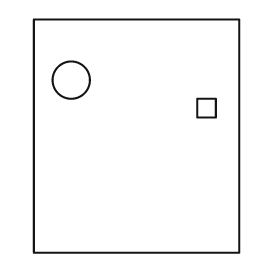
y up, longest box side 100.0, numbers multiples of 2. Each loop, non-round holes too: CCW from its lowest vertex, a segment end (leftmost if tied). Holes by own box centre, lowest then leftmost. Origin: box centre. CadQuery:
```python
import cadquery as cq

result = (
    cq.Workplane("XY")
    .moveTo(-44.0, -50.0)
    .lineTo(44.0, -50.0)
    .lineTo(44.0, 50.0)
    .lineTo(-44.0, 50.0)
    .close()
    .moveTo(26.0, 8.0)
    .lineTo(34.0, 8.0)
    .lineTo(34.0, 16.0)
    .lineTo(26.0, 16.0)
    .close()
    .moveTo(-28.0, 24.0)
    .circle(8.0)
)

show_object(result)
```